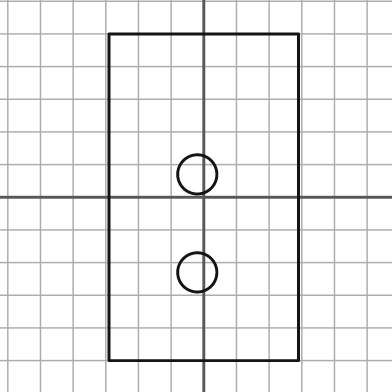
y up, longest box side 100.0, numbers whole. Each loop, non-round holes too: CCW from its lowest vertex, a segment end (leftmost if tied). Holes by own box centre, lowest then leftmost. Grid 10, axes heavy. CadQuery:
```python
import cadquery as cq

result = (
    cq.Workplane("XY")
    .moveTo(-29.0, -50.0)
    .lineTo(29.0, -50.0)
    .lineTo(29.0, 50.0)
    .lineTo(-29.0, 50.0)
    .close()
    .moveTo(-2.0, -23.0)
    .circle(6.0)
    .moveTo(-2.0, 7.0)
    .circle(6.0)
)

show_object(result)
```